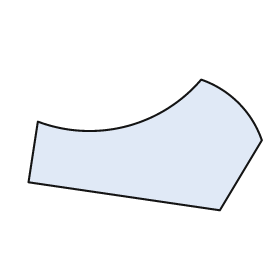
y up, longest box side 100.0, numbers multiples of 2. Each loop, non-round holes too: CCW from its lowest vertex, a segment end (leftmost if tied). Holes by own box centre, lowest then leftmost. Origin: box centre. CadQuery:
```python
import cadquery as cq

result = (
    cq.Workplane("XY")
    .moveTo(32.0, -28.0)
    .lineTo(50.0, 2.0)
    .threePointArc((40.0, 18.0), (24.0, 28.0))
    .threePointArc((-8.0, 8.0), (-46.0, 10.0))
    .lineTo(-50.0, -16.0)
    .close()
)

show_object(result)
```